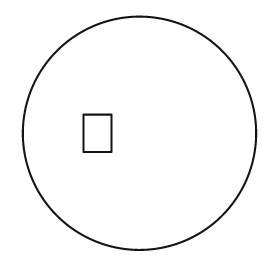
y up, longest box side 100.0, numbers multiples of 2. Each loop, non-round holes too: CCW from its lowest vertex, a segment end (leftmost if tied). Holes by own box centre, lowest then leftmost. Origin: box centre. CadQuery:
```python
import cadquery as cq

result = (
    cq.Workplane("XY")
    .moveTo(0.0, 0.0)
    .circle(50.0)
    .moveTo(-24.0, -8.0)
    .lineTo(-12.0, -8.0)
    .lineTo(-12.0, 8.0)
    .lineTo(-24.0, 8.0)
    .close()
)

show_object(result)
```